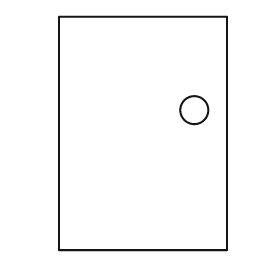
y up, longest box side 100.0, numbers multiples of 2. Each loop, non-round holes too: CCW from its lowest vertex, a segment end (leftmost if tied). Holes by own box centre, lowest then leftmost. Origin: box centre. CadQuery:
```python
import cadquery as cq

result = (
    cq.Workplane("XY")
    .moveTo(-36.0, -50.0)
    .lineTo(36.0, -50.0)
    .lineTo(36.0, 50.0)
    .lineTo(-36.0, 50.0)
    .close()
    .moveTo(22.0, 10.0)
    .circle(6.0)
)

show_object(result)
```